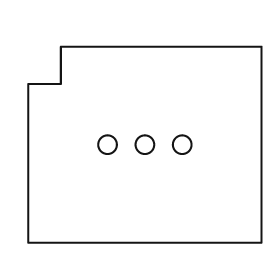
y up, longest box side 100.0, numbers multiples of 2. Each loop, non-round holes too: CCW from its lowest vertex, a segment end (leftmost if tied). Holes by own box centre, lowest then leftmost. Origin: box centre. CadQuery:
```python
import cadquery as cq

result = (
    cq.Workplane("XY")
    .moveTo(-50.0, -42.0)
    .lineTo(50.0, -42.0)
    .lineTo(50.0, 42.0)
    .lineTo(-36.0, 42.0)
    .lineTo(-36.0, 26.0)
    .lineTo(-50.0, 26.0)
    .close()
    .moveTo(-16.0, 0.0)
    .circle(4.0)
    .moveTo(0.0, 0.0)
    .circle(4.0)
    .moveTo(16.0, 0.0)
    .circle(4.0)
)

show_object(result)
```